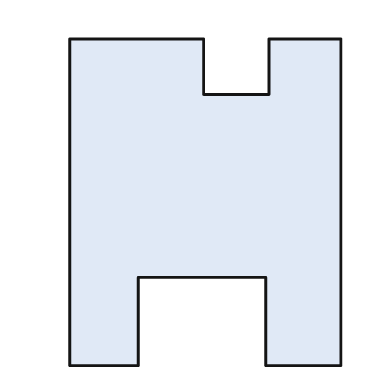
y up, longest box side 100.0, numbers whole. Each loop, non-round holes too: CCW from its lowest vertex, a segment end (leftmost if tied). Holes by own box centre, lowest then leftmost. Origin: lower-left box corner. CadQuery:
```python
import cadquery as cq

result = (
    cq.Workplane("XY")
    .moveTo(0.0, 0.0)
    .lineTo(21.0, 0.0)
    .lineTo(21.0, 27.0)
    .lineTo(60.0, 27.0)
    .lineTo(60.0, 0.0)
    .lineTo(83.0, 0.0)
    .lineTo(83.0, 100.0)
    .lineTo(61.0, 100.0)
    .lineTo(61.0, 83.0)
    .lineTo(41.0, 83.0)
    .lineTo(41.0, 100.0)
    .lineTo(0.0, 100.0)
    .close()
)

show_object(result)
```